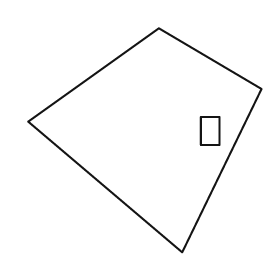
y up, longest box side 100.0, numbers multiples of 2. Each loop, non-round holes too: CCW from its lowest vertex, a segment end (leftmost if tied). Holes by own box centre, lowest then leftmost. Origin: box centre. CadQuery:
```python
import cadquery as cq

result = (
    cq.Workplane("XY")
    .moveTo(16.0, -48.0)
    .lineTo(50.0, 22.0)
    .lineTo(6.0, 48.0)
    .lineTo(-50.0, 8.0)
    .close()
    .moveTo(24.0, -2.0)
    .lineTo(32.0, -2.0)
    .lineTo(32.0, 10.0)
    .lineTo(24.0, 10.0)
    .close()
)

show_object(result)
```